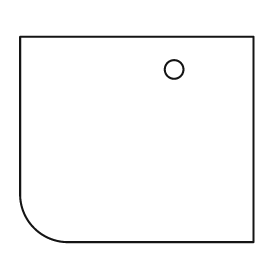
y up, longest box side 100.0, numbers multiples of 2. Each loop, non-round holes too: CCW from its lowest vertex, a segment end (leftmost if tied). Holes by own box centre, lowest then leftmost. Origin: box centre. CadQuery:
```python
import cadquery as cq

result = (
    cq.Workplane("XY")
    .moveTo(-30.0, -44.0)
    .lineTo(50.0, -44.0)
    .lineTo(50.0, 44.0)
    .lineTo(-50.0, 44.0)
    .lineTo(-50.0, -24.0)
    .threePointArc((-44.0, -38.0), (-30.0, -44.0))
    .close()
    .moveTo(16.0, 30.0)
    .circle(4.0)
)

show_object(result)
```